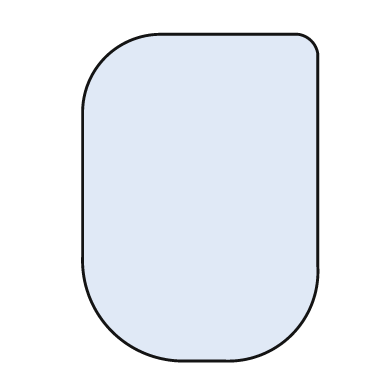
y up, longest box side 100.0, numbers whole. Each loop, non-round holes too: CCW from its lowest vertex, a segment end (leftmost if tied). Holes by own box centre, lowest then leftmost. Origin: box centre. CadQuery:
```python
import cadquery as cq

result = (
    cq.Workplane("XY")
    .moveTo(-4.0, -50.0)
    .lineTo(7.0, -50.0)
    .threePointArc((28.0, -42.0), (36.0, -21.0))
    .lineTo(36.0, 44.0)
    .threePointArc((34.0, 48.0), (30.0, 50.0))
    .lineTo(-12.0, 50.0)
    .threePointArc((-29.0, 43.0), (-36.0, 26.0))
    .lineTo(-36.0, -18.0)
    .threePointArc((-27.0, -41.0), (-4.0, -50.0))
    .close()
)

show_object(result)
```